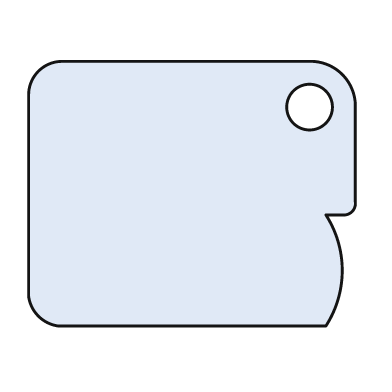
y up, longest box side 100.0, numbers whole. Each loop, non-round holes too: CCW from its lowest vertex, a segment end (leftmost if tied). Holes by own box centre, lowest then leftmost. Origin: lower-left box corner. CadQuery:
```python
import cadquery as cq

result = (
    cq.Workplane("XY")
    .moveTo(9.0, 0.0)
    .lineTo(91.0, 0.0)
    .threePointArc((96.0, 17.0), (91.0, 34.0))
    .lineTo(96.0, 34.0)
    .threePointArc((99.0, 35.0), (100.0, 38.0))
    .lineTo(100.0, 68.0)
    .threePointArc((96.0, 77.0), (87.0, 81.0))
    .lineTo(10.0, 81.0)
    .threePointArc((3.0, 78.0), (0.0, 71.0))
    .lineTo(0.0, 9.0)
    .threePointArc((3.0, 3.0), (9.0, 0.0))
    .close()
    .moveTo(86.0, 67.0)
    .circle(7.0)
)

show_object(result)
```